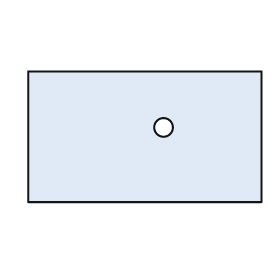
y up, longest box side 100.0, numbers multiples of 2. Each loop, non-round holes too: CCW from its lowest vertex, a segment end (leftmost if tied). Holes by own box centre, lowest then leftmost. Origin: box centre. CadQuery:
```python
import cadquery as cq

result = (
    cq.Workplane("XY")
    .moveTo(-50.0, -28.0)
    .lineTo(50.0, -28.0)
    .lineTo(50.0, 28.0)
    .lineTo(-50.0, 28.0)
    .close()
    .moveTo(8.0, 4.0)
    .circle(4.0)
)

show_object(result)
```